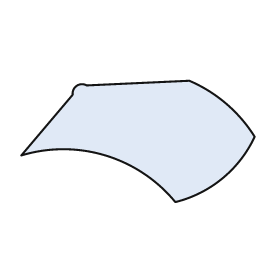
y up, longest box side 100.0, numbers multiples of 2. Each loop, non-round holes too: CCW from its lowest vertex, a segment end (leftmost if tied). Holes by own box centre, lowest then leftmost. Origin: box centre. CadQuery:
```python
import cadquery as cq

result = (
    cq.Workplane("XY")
    .moveTo(16.0, -26.0)
    .threePointArc((36.0, -16.0), (50.0, 2.0))
    .threePointArc((38.0, 16.0), (22.0, 26.0))
    .lineTo(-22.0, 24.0)
    .threePointArc((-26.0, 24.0), (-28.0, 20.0))
    .lineTo(-50.0, -6.0)
    .threePointArc((-14.0, -6.0), (16.0, -26.0))
    .close()
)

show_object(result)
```